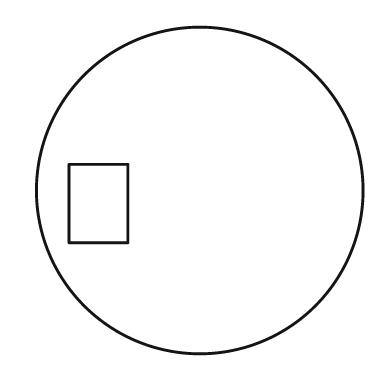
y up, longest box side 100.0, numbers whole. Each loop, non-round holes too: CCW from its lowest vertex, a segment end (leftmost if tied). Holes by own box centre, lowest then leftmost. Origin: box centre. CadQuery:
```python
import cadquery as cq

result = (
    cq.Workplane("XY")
    .moveTo(0.0, 0.0)
    .circle(50.0)
    .moveTo(-40.0, -16.0)
    .lineTo(-22.0, -16.0)
    .lineTo(-22.0, 8.0)
    .lineTo(-40.0, 8.0)
    .close()
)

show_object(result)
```